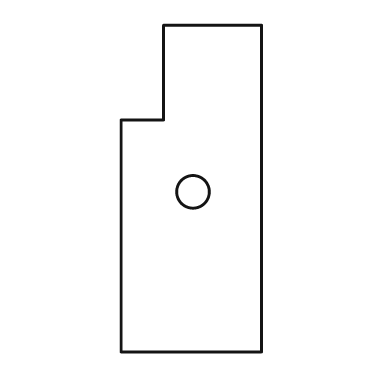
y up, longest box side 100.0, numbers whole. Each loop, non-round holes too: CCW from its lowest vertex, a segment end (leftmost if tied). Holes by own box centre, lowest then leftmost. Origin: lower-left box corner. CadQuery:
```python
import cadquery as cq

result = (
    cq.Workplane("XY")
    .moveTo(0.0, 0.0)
    .lineTo(43.0, 0.0)
    .lineTo(43.0, 100.0)
    .lineTo(13.0, 100.0)
    .lineTo(13.0, 71.0)
    .lineTo(0.0, 71.0)
    .close()
    .moveTo(22.0, 49.0)
    .circle(5.0)
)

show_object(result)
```